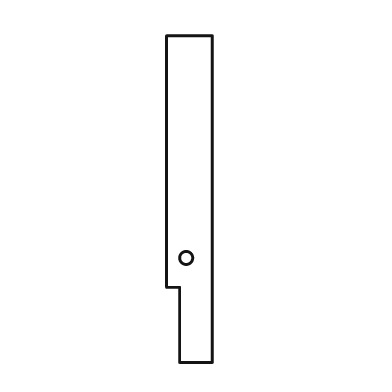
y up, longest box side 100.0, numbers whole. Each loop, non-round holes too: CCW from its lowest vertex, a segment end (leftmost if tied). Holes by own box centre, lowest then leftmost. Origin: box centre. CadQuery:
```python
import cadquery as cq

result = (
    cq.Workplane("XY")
    .moveTo(-3.0, -50.0)
    .lineTo(7.0, -50.0)
    .lineTo(7.0, 50.0)
    .lineTo(-7.0, 50.0)
    .lineTo(-7.0, -27.0)
    .lineTo(-3.0, -27.0)
    .close()
    .moveTo(-1.0, -18.0)
    .circle(2.0)
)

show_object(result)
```